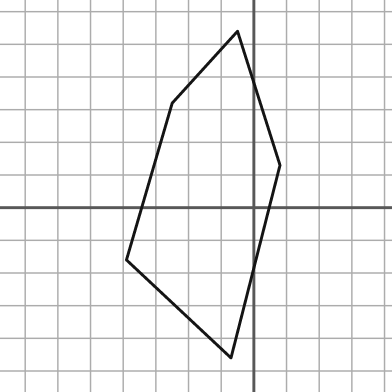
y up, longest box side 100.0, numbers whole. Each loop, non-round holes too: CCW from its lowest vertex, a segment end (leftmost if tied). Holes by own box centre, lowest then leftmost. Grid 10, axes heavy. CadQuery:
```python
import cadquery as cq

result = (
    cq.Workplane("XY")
    .moveTo(-7.0, -46.0)
    .lineTo(8.0, 13.0)
    .lineTo(-5.0, 54.0)
    .lineTo(-25.0, 32.0)
    .lineTo(-39.0, -16.0)
    .close()
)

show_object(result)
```